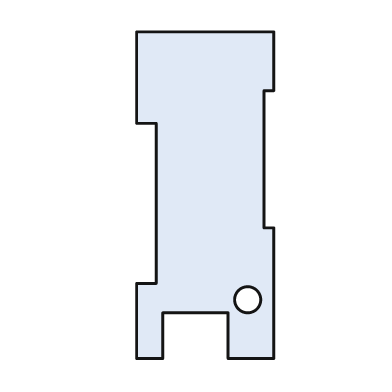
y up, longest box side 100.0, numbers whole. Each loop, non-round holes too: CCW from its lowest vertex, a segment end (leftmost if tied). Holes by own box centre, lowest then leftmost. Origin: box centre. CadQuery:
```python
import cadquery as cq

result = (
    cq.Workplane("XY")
    .moveTo(-21.0, -50.0)
    .lineTo(-13.0, -50.0)
    .lineTo(-13.0, -36.0)
    .lineTo(7.0, -36.0)
    .lineTo(7.0, -50.0)
    .lineTo(21.0, -50.0)
    .lineTo(21.0, -10.0)
    .lineTo(18.0, -10.0)
    .lineTo(18.0, 32.0)
    .lineTo(21.0, 32.0)
    .lineTo(21.0, 50.0)
    .lineTo(-21.0, 50.0)
    .lineTo(-21.0, 22.0)
    .lineTo(-15.0, 22.0)
    .lineTo(-15.0, -27.0)
    .lineTo(-21.0, -27.0)
    .close()
    .moveTo(13.0, -32.0)
    .circle(4.0)
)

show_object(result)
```